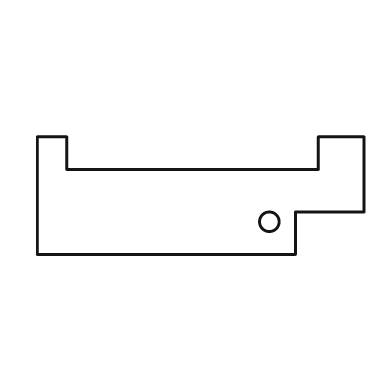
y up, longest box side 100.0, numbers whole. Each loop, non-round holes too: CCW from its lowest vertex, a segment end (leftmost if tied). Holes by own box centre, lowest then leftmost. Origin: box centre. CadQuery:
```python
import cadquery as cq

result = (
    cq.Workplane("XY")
    .moveTo(-50.0, -18.0)
    .lineTo(29.0, -18.0)
    .lineTo(29.0, -5.0)
    .lineTo(50.0, -5.0)
    .lineTo(50.0, 18.0)
    .lineTo(36.0, 18.0)
    .lineTo(36.0, 8.0)
    .lineTo(-41.0, 8.0)
    .lineTo(-41.0, 18.0)
    .lineTo(-50.0, 18.0)
    .close()
    .moveTo(21.0, -8.0)
    .circle(3.0)
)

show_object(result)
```